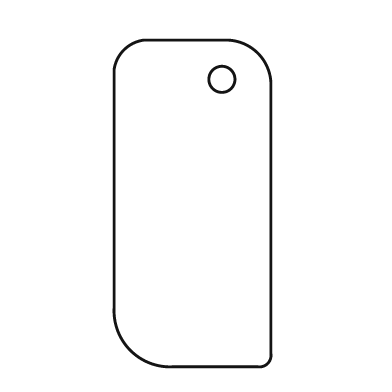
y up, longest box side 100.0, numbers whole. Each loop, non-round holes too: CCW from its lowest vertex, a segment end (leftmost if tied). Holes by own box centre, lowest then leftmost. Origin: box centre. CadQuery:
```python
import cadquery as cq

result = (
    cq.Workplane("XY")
    .moveTo(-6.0, -50.0)
    .lineTo(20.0, -50.0)
    .threePointArc((23.0, -49.0), (24.0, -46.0))
    .lineTo(24.0, 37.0)
    .threePointArc((20.0, 46.0), (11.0, 50.0))
    .lineTo(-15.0, 50.0)
    .threePointArc((-21.0, 47.0), (-24.0, 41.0))
    .lineTo(-24.0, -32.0)
    .threePointArc((-19.0, -45.0), (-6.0, -50.0))
    .close()
    .moveTo(9.0, 38.0)
    .circle(4.0)
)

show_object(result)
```